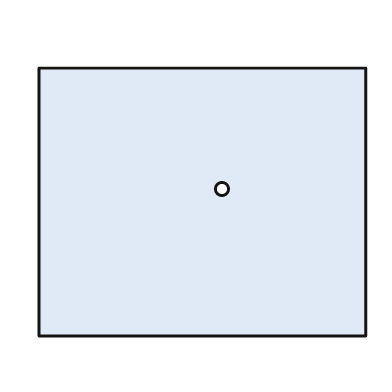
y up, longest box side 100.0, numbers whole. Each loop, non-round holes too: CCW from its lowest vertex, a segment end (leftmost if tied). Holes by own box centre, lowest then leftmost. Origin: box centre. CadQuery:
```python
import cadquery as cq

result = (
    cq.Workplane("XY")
    .moveTo(-50.0, -41.0)
    .lineTo(50.0, -41.0)
    .lineTo(50.0, 41.0)
    .lineTo(-50.0, 41.0)
    .close()
    .moveTo(6.0, 4.0)
    .circle(2.0)
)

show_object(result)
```